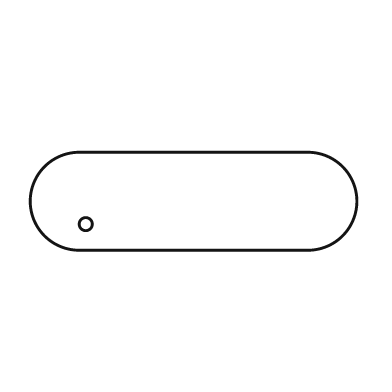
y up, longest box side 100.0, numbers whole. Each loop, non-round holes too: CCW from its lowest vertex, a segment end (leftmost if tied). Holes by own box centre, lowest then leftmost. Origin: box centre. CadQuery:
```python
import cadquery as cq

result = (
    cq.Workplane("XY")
    .moveTo(-35.0, -15.0)
    .lineTo(35.0, -15.0)
    .threePointArc((50.0, 0.0), (35.0, 15.0))
    .lineTo(-35.0, 15.0)
    .threePointArc((-50.0, 0.0), (-35.0, -15.0))
    .close()
    .moveTo(-33.0, -7.0)
    .circle(2.0)
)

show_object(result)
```